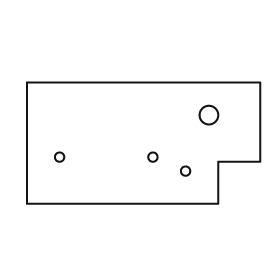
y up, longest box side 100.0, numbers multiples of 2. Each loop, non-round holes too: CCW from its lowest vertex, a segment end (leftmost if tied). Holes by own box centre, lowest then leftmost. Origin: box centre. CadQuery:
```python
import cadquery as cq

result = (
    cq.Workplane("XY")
    .moveTo(-50.0, -26.0)
    .lineTo(32.0, -26.0)
    .lineTo(32.0, -8.0)
    .lineTo(50.0, -8.0)
    .lineTo(50.0, 26.0)
    .lineTo(-50.0, 26.0)
    .close()
    .moveTo(18.0, -12.0)
    .circle(2.0)
    .moveTo(-36.0, -6.0)
    .circle(2.0)
    .moveTo(4.0, -6.0)
    .circle(2.0)
    .moveTo(28.0, 12.0)
    .circle(4.0)
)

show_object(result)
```